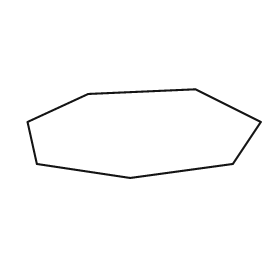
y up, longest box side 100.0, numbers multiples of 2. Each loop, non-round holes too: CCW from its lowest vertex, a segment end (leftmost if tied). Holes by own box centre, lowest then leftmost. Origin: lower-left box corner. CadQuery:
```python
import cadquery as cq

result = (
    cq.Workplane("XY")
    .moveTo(44.0, 0.0)
    .lineTo(88.0, 6.0)
    .lineTo(100.0, 24.0)
    .lineTo(72.0, 38.0)
    .lineTo(26.0, 36.0)
    .lineTo(0.0, 24.0)
    .lineTo(4.0, 6.0)
    .close()
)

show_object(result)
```